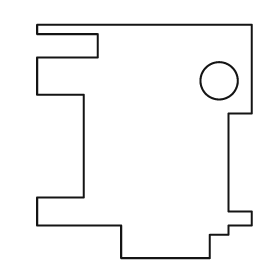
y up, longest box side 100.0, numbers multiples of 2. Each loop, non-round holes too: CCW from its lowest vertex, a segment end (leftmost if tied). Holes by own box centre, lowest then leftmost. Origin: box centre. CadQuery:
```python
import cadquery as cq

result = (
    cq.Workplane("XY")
    .moveTo(-10.0, -50.0)
    .lineTo(28.0, -50.0)
    .lineTo(28.0, -40.0)
    .lineTo(36.0, -40.0)
    .lineTo(36.0, -36.0)
    .lineTo(46.0, -36.0)
    .lineTo(46.0, -30.0)
    .lineTo(36.0, -30.0)
    .lineTo(36.0, 12.0)
    .lineTo(46.0, 12.0)
    .lineTo(46.0, 50.0)
    .lineTo(-46.0, 50.0)
    .lineTo(-46.0, 46.0)
    .lineTo(-20.0, 46.0)
    .lineTo(-20.0, 36.0)
    .lineTo(-46.0, 36.0)
    .lineTo(-46.0, 20.0)
    .lineTo(-26.0, 20.0)
    .lineTo(-26.0, -24.0)
    .lineTo(-46.0, -24.0)
    .lineTo(-46.0, -36.0)
    .lineTo(-10.0, -36.0)
    .close()
    .moveTo(32.0, 26.0)
    .circle(8.0)
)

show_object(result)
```